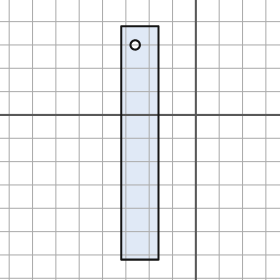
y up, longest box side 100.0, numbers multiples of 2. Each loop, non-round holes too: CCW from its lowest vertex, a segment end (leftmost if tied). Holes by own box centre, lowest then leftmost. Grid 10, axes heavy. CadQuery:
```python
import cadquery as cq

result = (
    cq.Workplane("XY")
    .moveTo(-32.0, -62.0)
    .lineTo(-16.0, -62.0)
    .lineTo(-16.0, 38.0)
    .lineTo(-32.0, 38.0)
    .close()
    .moveTo(-26.0, 30.0)
    .circle(2.0)
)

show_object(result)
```